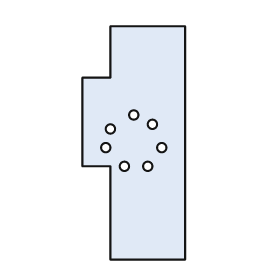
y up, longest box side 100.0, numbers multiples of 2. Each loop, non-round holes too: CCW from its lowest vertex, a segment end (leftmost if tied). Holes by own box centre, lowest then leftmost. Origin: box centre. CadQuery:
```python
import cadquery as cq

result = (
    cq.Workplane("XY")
    .moveTo(-10.0, -50.0)
    .lineTo(22.0, -50.0)
    .lineTo(22.0, 50.0)
    .lineTo(-10.0, 50.0)
    .lineTo(-10.0, 28.0)
    .lineTo(-22.0, 28.0)
    .lineTo(-22.0, -10.0)
    .lineTo(-10.0, -10.0)
    .close()
    .moveTo(-4.0, -10.0)
    .circle(2.0)
    .moveTo(6.0, -10.0)
    .circle(2.0)
    .moveTo(-12.0, -2.0)
    .circle(2.0)
    .moveTo(12.0, -2.0)
    .circle(2.0)
    .moveTo(-10.0, 6.0)
    .circle(2.0)
    .moveTo(8.0, 8.0)
    .circle(2.0)
    .moveTo(0.0, 12.0)
    .circle(2.0)
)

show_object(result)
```